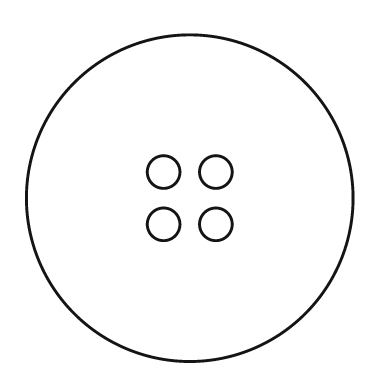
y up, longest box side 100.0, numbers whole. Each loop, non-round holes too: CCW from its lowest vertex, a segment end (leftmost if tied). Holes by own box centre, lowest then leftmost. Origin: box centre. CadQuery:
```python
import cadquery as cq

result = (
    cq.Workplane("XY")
    .moveTo(0.0, 0.0)
    .circle(50.0)
    .moveTo(-8.0, -8.0)
    .circle(5.0)
    .moveTo(8.0, -8.0)
    .circle(5.0)
    .moveTo(-8.0, 8.0)
    .circle(5.0)
    .moveTo(8.0, 8.0)
    .circle(5.0)
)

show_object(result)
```